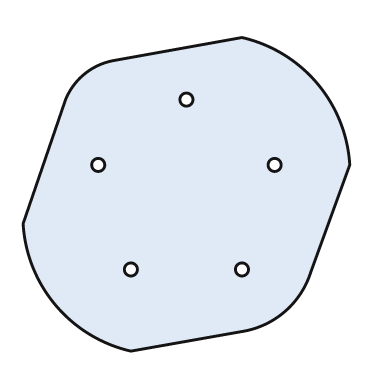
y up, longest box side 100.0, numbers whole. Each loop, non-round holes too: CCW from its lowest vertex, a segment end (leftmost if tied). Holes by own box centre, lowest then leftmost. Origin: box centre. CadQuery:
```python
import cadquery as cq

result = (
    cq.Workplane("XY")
    .moveTo(-17.0, -48.0)
    .lineTo(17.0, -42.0)
    .threePointArc((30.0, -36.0), (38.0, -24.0))
    .lineTo(50.0, 9.0)
    .threePointArc((40.0, 34.0), (17.0, 48.0))
    .lineTo(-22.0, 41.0)
    .threePointArc((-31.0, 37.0), (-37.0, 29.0))
    .lineTo(-50.0, -9.0)
    .threePointArc((-40.0, -34.0), (-17.0, -48.0))
    .close()
    .moveTo(-17.0, -23.0)
    .circle(2.0)
    .moveTo(17.0, -23.0)
    .circle(2.0)
    .moveTo(-27.0, 9.0)
    .circle(2.0)
    .moveTo(27.0, 9.0)
    .circle(2.0)
    .moveTo(0.0, 29.0)
    .circle(2.0)
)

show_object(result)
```